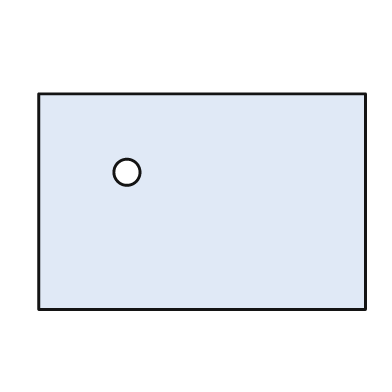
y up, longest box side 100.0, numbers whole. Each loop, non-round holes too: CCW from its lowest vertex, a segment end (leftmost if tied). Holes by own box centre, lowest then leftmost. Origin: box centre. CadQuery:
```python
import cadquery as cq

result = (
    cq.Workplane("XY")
    .moveTo(-50.0, -33.0)
    .lineTo(50.0, -33.0)
    .lineTo(50.0, 33.0)
    .lineTo(-50.0, 33.0)
    .close()
    .moveTo(-23.0, 9.0)
    .circle(4.0)
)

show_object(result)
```